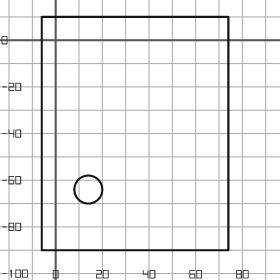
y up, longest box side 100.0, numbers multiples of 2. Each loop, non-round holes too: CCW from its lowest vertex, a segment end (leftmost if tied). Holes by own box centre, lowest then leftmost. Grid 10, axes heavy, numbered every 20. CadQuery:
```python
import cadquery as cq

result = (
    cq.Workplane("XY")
    .moveTo(-6.0, -90.0)
    .lineTo(74.0, -90.0)
    .lineTo(74.0, 10.0)
    .lineTo(-6.0, 10.0)
    .close()
    .moveTo(14.0, -64.0)
    .circle(6.0)
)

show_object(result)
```